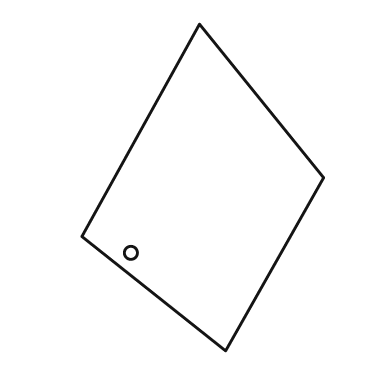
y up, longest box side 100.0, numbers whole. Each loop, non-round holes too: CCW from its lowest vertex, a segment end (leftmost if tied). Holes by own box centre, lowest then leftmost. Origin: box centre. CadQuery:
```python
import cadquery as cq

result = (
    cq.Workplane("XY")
    .moveTo(7.0, -50.0)
    .lineTo(37.0, 3.0)
    .lineTo(-1.0, 50.0)
    .lineTo(-37.0, -15.0)
    .close()
    .moveTo(-22.0, -20.0)
    .circle(2.0)
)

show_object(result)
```